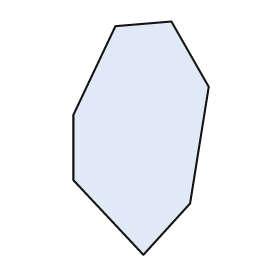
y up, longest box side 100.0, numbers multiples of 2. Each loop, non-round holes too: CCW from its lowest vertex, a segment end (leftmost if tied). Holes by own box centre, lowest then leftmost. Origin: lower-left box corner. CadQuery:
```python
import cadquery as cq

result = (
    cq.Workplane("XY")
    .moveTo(30.0, 0.0)
    .lineTo(50.0, 22.0)
    .lineTo(58.0, 72.0)
    .lineTo(42.0, 100.0)
    .lineTo(18.0, 98.0)
    .lineTo(0.0, 60.0)
    .lineTo(0.0, 32.0)
    .close()
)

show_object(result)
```